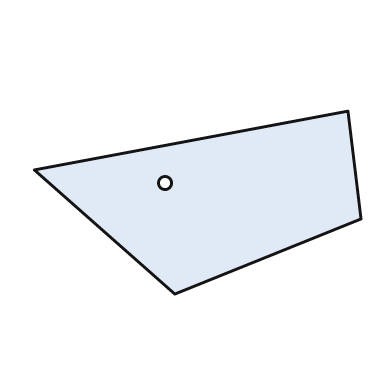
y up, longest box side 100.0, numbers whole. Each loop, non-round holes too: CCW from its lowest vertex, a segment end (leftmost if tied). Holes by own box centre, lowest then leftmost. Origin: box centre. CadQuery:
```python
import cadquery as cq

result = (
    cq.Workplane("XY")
    .moveTo(-7.0, -28.0)
    .lineTo(50.0, -5.0)
    .lineTo(46.0, 28.0)
    .lineTo(-50.0, 10.0)
    .close()
    .moveTo(-10.0, 6.0)
    .circle(2.0)
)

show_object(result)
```